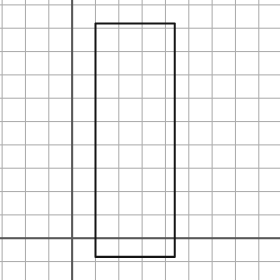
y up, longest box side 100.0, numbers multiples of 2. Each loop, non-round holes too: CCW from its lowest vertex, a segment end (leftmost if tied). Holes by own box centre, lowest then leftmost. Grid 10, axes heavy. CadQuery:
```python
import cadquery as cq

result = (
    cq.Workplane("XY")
    .moveTo(10.0, -8.0)
    .lineTo(44.0, -8.0)
    .lineTo(44.0, 92.0)
    .lineTo(10.0, 92.0)
    .close()
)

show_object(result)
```